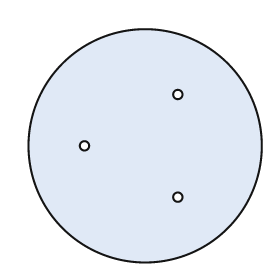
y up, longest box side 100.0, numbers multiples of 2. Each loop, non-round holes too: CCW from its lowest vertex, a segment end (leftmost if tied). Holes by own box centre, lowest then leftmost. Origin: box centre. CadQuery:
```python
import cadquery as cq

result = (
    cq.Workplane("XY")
    .moveTo(0.0, 0.0)
    .circle(50.0)
    .moveTo(14.0, -22.0)
    .circle(2.0)
    .moveTo(-26.0, 0.0)
    .circle(2.0)
    .moveTo(14.0, 22.0)
    .circle(2.0)
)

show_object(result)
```